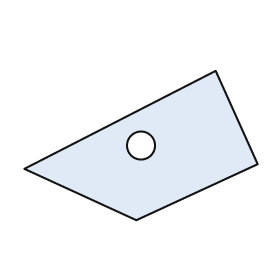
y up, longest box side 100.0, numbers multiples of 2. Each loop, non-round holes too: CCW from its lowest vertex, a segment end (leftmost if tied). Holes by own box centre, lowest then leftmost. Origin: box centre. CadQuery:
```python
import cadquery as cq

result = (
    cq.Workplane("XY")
    .moveTo(-2.0, -32.0)
    .lineTo(50.0, -8.0)
    .lineTo(32.0, 32.0)
    .lineTo(-50.0, -10.0)
    .close()
    .moveTo(0.0, 0.0)
    .circle(6.0)
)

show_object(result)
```